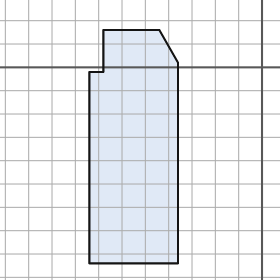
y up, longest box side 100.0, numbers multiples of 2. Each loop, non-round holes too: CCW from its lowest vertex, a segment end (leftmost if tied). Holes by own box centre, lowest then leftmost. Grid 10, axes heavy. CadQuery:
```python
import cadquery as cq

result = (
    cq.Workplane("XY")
    .moveTo(-74.0, -84.0)
    .lineTo(-36.0, -84.0)
    .lineTo(-36.0, 2.0)
    .lineTo(-44.0, 16.0)
    .lineTo(-68.0, 16.0)
    .lineTo(-68.0, -2.0)
    .lineTo(-74.0, -2.0)
    .close()
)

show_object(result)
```